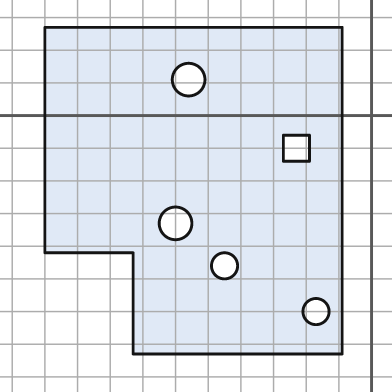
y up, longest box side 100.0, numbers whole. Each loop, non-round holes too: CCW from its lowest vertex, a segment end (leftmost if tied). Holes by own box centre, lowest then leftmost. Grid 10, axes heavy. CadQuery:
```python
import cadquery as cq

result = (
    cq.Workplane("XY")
    .moveTo(-73.0, -73.0)
    .lineTo(-9.0, -73.0)
    .lineTo(-9.0, 27.0)
    .lineTo(-100.0, 27.0)
    .lineTo(-100.0, -42.0)
    .lineTo(-73.0, -42.0)
    .close()
    .moveTo(-17.0, -60.0)
    .circle(4.0)
    .moveTo(-45.0, -46.0)
    .circle(4.0)
    .moveTo(-60.0, -33.0)
    .circle(5.0)
    .moveTo(-27.0, -14.0)
    .lineTo(-19.0, -14.0)
    .lineTo(-19.0, -6.0)
    .lineTo(-27.0, -6.0)
    .close()
    .moveTo(-56.0, 11.0)
    .circle(5.0)
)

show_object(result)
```